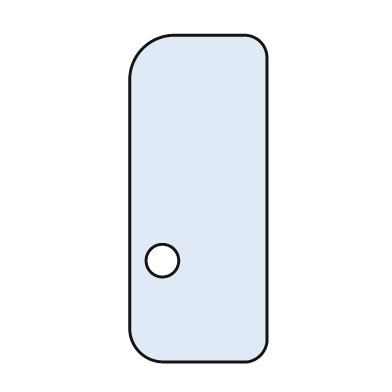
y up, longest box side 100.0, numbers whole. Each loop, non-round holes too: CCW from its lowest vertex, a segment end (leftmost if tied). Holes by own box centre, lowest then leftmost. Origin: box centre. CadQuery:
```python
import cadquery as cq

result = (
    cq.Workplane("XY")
    .moveTo(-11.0, -50.0)
    .lineTo(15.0, -50.0)
    .threePointArc((19.0, -48.0), (21.0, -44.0))
    .lineTo(21.0, 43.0)
    .threePointArc((19.0, 48.0), (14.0, 50.0))
    .lineTo(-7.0, 50.0)
    .threePointArc((-17.0, 46.0), (-21.0, 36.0))
    .lineTo(-21.0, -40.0)
    .threePointArc((-18.0, -47.0), (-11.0, -50.0))
    .close()
    .moveTo(-11.0, -19.0)
    .circle(5.0)
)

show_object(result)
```